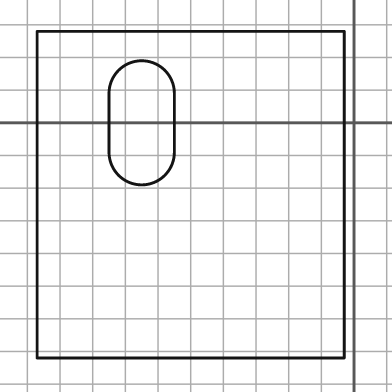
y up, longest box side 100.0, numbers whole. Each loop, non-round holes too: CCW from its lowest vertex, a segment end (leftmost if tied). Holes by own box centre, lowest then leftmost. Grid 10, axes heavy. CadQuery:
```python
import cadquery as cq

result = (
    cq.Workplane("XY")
    .moveTo(-97.0, -72.0)
    .lineTo(-3.0, -72.0)
    .lineTo(-3.0, 28.0)
    .lineTo(-97.0, 28.0)
    .close()
    .moveTo(-75.0, -9.0)
    .threePointArc((-65.0, -19.0), (-55.0, -9.0))
    .lineTo(-55.0, 9.0)
    .threePointArc((-65.0, 19.0), (-75.0, 9.0))
    .close()
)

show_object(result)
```